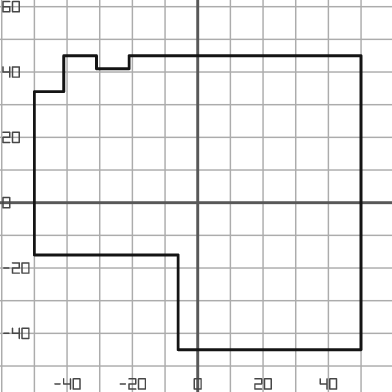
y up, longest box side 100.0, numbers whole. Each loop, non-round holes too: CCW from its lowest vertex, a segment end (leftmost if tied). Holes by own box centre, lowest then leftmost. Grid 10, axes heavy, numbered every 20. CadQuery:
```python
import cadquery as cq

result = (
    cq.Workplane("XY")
    .moveTo(-6.0, -45.0)
    .lineTo(50.0, -45.0)
    .lineTo(50.0, 45.0)
    .lineTo(-21.0, 45.0)
    .lineTo(-21.0, 41.0)
    .lineTo(-31.0, 41.0)
    .lineTo(-31.0, 45.0)
    .lineTo(-41.0, 45.0)
    .lineTo(-41.0, 34.0)
    .lineTo(-50.0, 34.0)
    .lineTo(-50.0, -16.0)
    .lineTo(-6.0, -16.0)
    .close()
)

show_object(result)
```